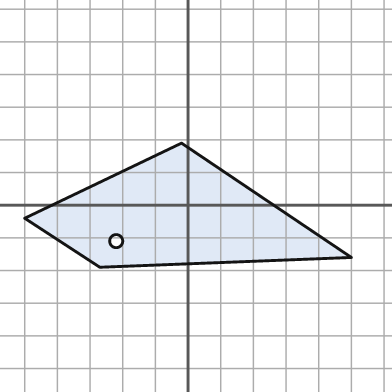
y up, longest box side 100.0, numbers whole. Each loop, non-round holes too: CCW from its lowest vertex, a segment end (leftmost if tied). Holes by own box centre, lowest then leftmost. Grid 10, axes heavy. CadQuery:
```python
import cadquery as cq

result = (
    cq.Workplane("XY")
    .moveTo(-27.0, -19.0)
    .lineTo(50.0, -16.0)
    .lineTo(-2.0, 19.0)
    .lineTo(-50.0, -4.0)
    .close()
    .moveTo(-22.0, -11.0)
    .circle(2.0)
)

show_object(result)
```